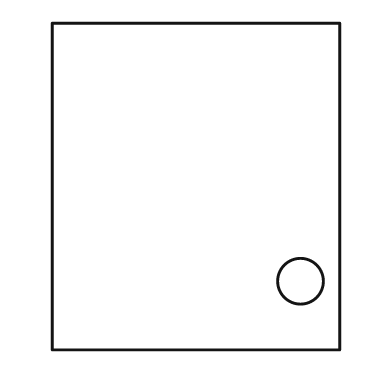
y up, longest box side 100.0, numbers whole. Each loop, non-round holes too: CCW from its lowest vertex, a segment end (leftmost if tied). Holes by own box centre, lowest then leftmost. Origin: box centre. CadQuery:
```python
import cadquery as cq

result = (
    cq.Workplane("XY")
    .moveTo(-44.0, -50.0)
    .lineTo(44.0, -50.0)
    .lineTo(44.0, 50.0)
    .lineTo(-44.0, 50.0)
    .close()
    .moveTo(32.0, -29.0)
    .circle(7.0)
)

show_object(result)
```